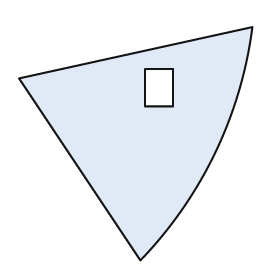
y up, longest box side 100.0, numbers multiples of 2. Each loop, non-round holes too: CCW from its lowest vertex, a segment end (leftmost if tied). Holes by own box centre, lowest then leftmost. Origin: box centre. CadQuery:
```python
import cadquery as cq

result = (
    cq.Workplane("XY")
    .moveTo(2.0, -50.0)
    .threePointArc((34.0, -4.0), (50.0, 50.0))
    .lineTo(-50.0, 28.0)
    .close()
    .moveTo(4.0, 16.0)
    .lineTo(16.0, 16.0)
    .lineTo(16.0, 32.0)
    .lineTo(4.0, 32.0)
    .close()
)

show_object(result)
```